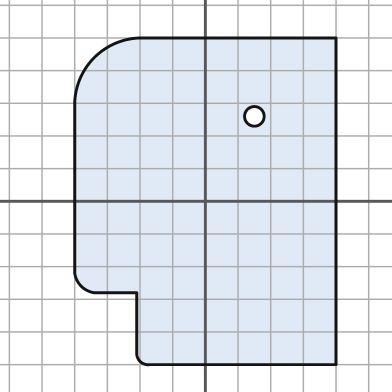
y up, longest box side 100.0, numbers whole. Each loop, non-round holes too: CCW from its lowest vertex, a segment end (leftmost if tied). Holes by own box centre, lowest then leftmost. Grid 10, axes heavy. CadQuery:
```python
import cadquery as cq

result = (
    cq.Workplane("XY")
    .moveTo(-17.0, -50.0)
    .lineTo(40.0, -50.0)
    .lineTo(40.0, 50.0)
    .lineTo(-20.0, 50.0)
    .threePointArc((-34.0, 44.0), (-40.0, 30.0))
    .lineTo(-40.0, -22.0)
    .threePointArc((-38.0, -26.0), (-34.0, -28.0))
    .lineTo(-21.0, -28.0)
    .lineTo(-21.0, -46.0)
    .threePointArc((-20.0, -49.0), (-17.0, -50.0))
    .close()
    .moveTo(15.0, 26.0)
    .circle(3.0)
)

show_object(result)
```